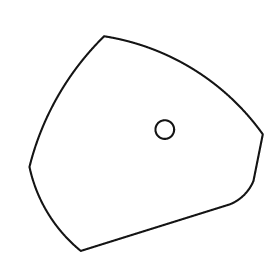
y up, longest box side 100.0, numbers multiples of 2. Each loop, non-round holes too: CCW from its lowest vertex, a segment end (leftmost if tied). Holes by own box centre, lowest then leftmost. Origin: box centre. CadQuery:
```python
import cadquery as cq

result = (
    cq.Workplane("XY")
    .moveTo(-28.0, -46.0)
    .lineTo(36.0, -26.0)
    .threePointArc((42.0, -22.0), (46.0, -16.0))
    .lineTo(50.0, 4.0)
    .threePointArc((20.0, 32.0), (-18.0, 46.0))
    .threePointArc((-38.0, 20.0), (-50.0, -10.0))
    .threePointArc((-42.0, -30.0), (-28.0, -46.0))
    .close()
    .moveTo(8.0, 6.0)
    .circle(4.0)
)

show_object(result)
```